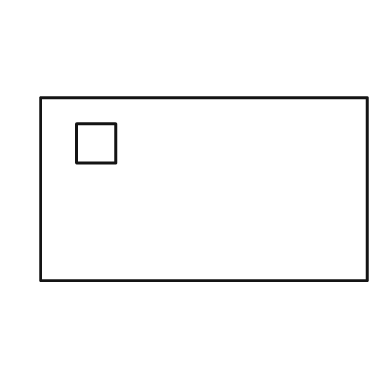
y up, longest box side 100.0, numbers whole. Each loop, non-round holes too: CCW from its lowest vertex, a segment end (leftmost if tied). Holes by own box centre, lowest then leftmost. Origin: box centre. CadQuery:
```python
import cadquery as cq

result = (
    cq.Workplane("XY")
    .moveTo(-50.0, -28.0)
    .lineTo(50.0, -28.0)
    .lineTo(50.0, 28.0)
    .lineTo(-50.0, 28.0)
    .close()
    .moveTo(-39.0, 8.0)
    .lineTo(-27.0, 8.0)
    .lineTo(-27.0, 20.0)
    .lineTo(-39.0, 20.0)
    .close()
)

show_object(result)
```